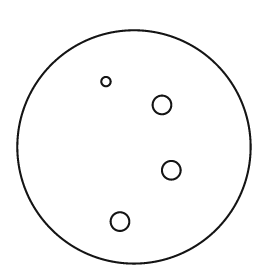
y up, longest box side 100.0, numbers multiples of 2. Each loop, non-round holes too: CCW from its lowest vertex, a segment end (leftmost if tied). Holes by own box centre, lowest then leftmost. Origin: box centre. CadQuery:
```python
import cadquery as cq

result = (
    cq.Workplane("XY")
    .moveTo(0.0, 0.0)
    .circle(50.0)
    .moveTo(-6.0, -32.0)
    .circle(4.0)
    .moveTo(16.0, -10.0)
    .circle(4.0)
    .moveTo(12.0, 18.0)
    .circle(4.0)
    .moveTo(-12.0, 28.0)
    .circle(2.0)
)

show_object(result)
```